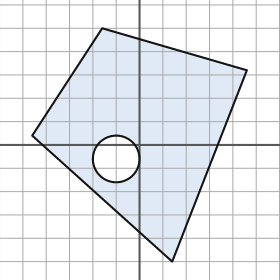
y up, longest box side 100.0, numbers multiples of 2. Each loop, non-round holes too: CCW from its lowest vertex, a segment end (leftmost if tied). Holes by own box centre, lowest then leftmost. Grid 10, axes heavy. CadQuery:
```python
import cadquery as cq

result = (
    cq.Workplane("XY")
    .moveTo(14.0, -50.0)
    .lineTo(46.0, 32.0)
    .lineTo(-16.0, 50.0)
    .lineTo(-46.0, 4.0)
    .close()
    .moveTo(-10.0, -6.0)
    .circle(10.0)
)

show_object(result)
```